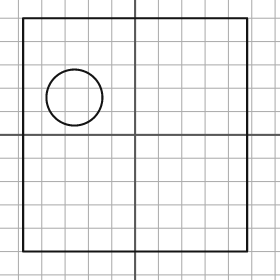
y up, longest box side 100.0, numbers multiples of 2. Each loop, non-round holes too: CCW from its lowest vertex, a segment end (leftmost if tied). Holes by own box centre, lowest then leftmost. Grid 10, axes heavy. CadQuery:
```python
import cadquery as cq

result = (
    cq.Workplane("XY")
    .moveTo(-48.0, -50.0)
    .lineTo(48.0, -50.0)
    .lineTo(48.0, 50.0)
    .lineTo(-48.0, 50.0)
    .close()
    .moveTo(-26.0, 16.0)
    .circle(12.0)
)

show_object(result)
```